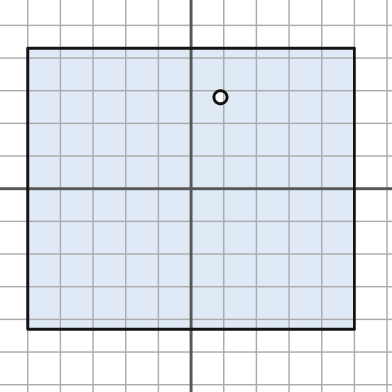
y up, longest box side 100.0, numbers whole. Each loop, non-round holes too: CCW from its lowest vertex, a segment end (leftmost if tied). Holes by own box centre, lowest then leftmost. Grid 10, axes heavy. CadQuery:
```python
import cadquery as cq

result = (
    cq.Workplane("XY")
    .moveTo(-50.0, -43.0)
    .lineTo(50.0, -43.0)
    .lineTo(50.0, 43.0)
    .lineTo(-50.0, 43.0)
    .close()
    .moveTo(9.0, 28.0)
    .circle(2.0)
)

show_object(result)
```